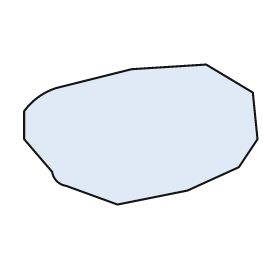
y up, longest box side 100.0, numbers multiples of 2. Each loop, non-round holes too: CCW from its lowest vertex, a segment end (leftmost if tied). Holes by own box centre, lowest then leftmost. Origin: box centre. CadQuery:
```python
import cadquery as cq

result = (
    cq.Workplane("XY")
    .moveTo(-10.0, -30.0)
    .lineTo(20.0, -24.0)
    .lineTo(42.0, -14.0)
    .lineTo(50.0, -2.0)
    .lineTo(48.0, 18.0)
    .lineTo(28.0, 30.0)
    .lineTo(-4.0, 28.0)
    .lineTo(-36.0, 20.0)
    .threePointArc((-44.0, 16.0), (-50.0, 10.0))
    .lineTo(-50.0, -2.0)
    .lineTo(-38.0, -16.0)
    .threePointArc((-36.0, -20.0), (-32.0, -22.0))
    .close()
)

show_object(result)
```